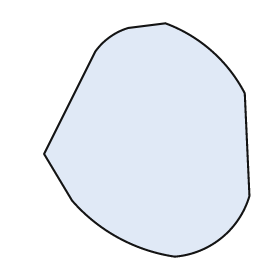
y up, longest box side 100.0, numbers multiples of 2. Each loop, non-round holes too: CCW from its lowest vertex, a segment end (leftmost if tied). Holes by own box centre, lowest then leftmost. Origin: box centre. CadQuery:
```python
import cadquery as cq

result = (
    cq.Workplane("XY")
    .moveTo(12.0, -50.0)
    .threePointArc((32.0, -42.0), (44.0, -24.0))
    .lineTo(42.0, 20.0)
    .threePointArc((28.0, 38.0), (8.0, 50.0))
    .lineTo(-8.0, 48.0)
    .threePointArc((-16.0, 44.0), (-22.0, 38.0))
    .lineTo(-44.0, -6.0)
    .lineTo(-32.0, -26.0)
    .threePointArc((-12.0, -42.0), (12.0, -50.0))
    .close()
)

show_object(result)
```